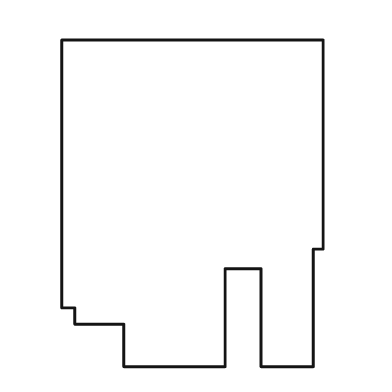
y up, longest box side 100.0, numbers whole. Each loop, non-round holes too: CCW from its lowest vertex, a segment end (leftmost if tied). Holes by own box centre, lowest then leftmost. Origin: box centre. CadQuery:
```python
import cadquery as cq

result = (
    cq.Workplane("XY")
    .moveTo(-21.0, -50.0)
    .lineTo(10.0, -50.0)
    .lineTo(10.0, -20.0)
    .lineTo(21.0, -20.0)
    .lineTo(21.0, -50.0)
    .lineTo(37.0, -50.0)
    .lineTo(37.0, -14.0)
    .lineTo(40.0, -14.0)
    .lineTo(40.0, 50.0)
    .lineTo(-40.0, 50.0)
    .lineTo(-40.0, -32.0)
    .lineTo(-36.0, -32.0)
    .lineTo(-36.0, -37.0)
    .lineTo(-21.0, -37.0)
    .close()
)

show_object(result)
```